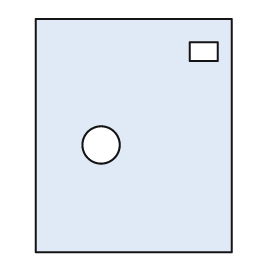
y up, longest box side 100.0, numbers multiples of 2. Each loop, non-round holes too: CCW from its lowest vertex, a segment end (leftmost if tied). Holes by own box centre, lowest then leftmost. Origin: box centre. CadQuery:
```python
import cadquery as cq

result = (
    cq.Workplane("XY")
    .moveTo(-42.0, -50.0)
    .lineTo(42.0, -50.0)
    .lineTo(42.0, 50.0)
    .lineTo(-42.0, 50.0)
    .close()
    .moveTo(-14.0, -4.0)
    .circle(8.0)
    .moveTo(24.0, 32.0)
    .lineTo(36.0, 32.0)
    .lineTo(36.0, 40.0)
    .lineTo(24.0, 40.0)
    .close()
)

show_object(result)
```